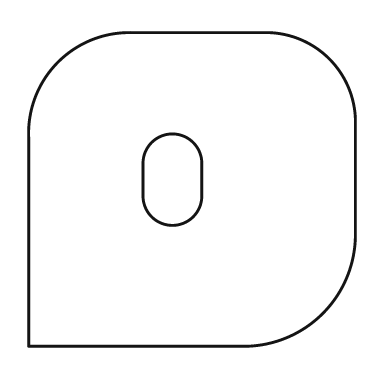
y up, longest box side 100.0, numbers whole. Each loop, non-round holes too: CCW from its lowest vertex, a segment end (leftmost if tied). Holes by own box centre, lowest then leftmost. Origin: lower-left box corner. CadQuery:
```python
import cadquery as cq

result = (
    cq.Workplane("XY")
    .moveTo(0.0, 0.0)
    .lineTo(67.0, 0.0)
    .threePointArc((90.0, 10.0), (100.0, 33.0))
    .lineTo(100.0, 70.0)
    .threePointArc((92.0, 88.0), (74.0, 96.0))
    .lineTo(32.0, 96.0)
    .threePointArc((9.0, 87.0), (0.0, 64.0))
    .close()
    .moveTo(35.0, 46.0)
    .threePointArc((44.0, 37.0), (53.0, 46.0))
    .lineTo(53.0, 56.0)
    .threePointArc((44.0, 65.0), (35.0, 56.0))
    .close()
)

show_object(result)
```